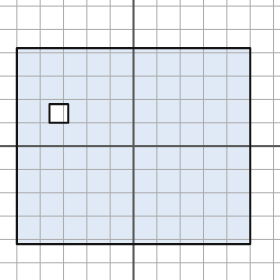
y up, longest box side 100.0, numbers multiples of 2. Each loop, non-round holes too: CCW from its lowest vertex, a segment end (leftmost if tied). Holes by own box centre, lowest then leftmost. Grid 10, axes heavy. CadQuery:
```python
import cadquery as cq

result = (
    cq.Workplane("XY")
    .moveTo(-50.0, -42.0)
    .lineTo(50.0, -42.0)
    .lineTo(50.0, 42.0)
    .lineTo(-50.0, 42.0)
    .close()
    .moveTo(-36.0, 10.0)
    .lineTo(-28.0, 10.0)
    .lineTo(-28.0, 18.0)
    .lineTo(-36.0, 18.0)
    .close()
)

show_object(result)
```